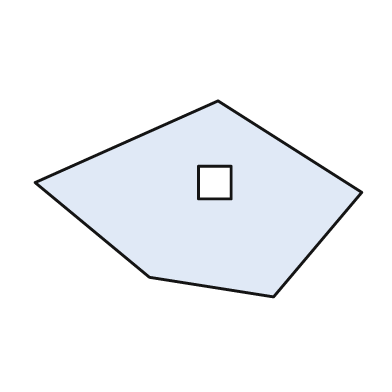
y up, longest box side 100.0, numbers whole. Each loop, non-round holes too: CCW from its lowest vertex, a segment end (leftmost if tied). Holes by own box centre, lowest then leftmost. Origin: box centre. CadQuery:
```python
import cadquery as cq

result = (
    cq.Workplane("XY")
    .moveTo(23.0, -30.0)
    .lineTo(50.0, 2.0)
    .lineTo(6.0, 30.0)
    .lineTo(-50.0, 5.0)
    .lineTo(-15.0, -24.0)
    .close()
    .moveTo(0.0, 0.0)
    .lineTo(10.0, 0.0)
    .lineTo(10.0, 10.0)
    .lineTo(0.0, 10.0)
    .close()
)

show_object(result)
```